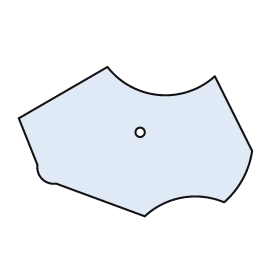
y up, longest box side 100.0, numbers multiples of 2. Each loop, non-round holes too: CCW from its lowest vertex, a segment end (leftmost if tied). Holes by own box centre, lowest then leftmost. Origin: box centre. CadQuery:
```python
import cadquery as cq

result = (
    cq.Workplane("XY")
    .moveTo(4.0, -32.0)
    .threePointArc((20.0, -24.0), (38.0, -26.0))
    .threePointArc((46.0, -16.0), (50.0, -4.0))
    .lineTo(34.0, 28.0)
    .threePointArc((10.0, 20.0), (-12.0, 32.0))
    .lineTo(-50.0, 10.0)
    .lineTo(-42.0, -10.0)
    .threePointArc((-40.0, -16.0), (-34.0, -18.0))
    .close()
    .moveTo(2.0, 4.0)
    .circle(2.0)
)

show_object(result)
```